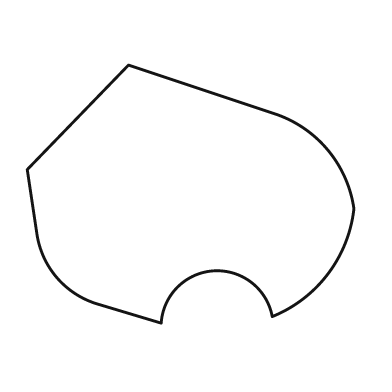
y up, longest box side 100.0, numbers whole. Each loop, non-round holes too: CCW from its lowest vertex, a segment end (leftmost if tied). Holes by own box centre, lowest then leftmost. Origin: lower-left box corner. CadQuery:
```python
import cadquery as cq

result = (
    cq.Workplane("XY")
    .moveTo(41.0, 0.0)
    .threePointArc((57.0, 16.0), (75.0, 2.0))
    .threePointArc((92.0, 15.0), (100.0, 35.0))
    .threePointArc((92.0, 53.0), (76.0, 64.0))
    .lineTo(31.0, 79.0)
    .lineTo(0.0, 47.0)
    .lineTo(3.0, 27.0)
    .threePointArc((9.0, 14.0), (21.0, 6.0))
    .close()
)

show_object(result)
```